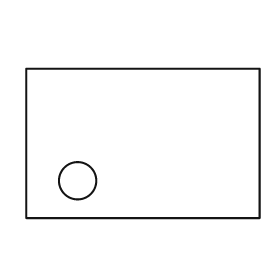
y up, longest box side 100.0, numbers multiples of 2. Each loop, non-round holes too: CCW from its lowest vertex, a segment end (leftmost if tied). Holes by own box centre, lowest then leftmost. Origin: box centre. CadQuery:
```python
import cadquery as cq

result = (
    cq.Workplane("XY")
    .moveTo(-50.0, -32.0)
    .lineTo(50.0, -32.0)
    .lineTo(50.0, 32.0)
    .lineTo(-50.0, 32.0)
    .close()
    .moveTo(-28.0, -16.0)
    .circle(8.0)
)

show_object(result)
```